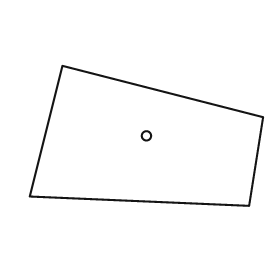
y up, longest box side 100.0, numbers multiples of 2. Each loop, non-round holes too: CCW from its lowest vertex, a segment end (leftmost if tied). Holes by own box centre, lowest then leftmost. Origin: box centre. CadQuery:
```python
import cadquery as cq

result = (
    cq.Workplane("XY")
    .moveTo(44.0, -30.0)
    .lineTo(50.0, 8.0)
    .lineTo(-36.0, 30.0)
    .lineTo(-50.0, -26.0)
    .close()
    .moveTo(0.0, 0.0)
    .circle(2.0)
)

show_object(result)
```